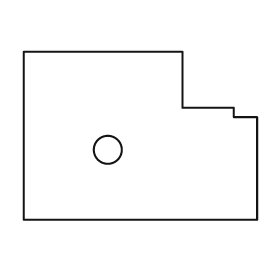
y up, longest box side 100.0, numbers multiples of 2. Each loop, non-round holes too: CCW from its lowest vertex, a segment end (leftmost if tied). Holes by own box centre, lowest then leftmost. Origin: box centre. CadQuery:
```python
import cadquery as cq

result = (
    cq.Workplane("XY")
    .moveTo(-50.0, -36.0)
    .lineTo(50.0, -36.0)
    .lineTo(50.0, 8.0)
    .lineTo(40.0, 8.0)
    .lineTo(40.0, 12.0)
    .lineTo(18.0, 12.0)
    .lineTo(18.0, 36.0)
    .lineTo(-50.0, 36.0)
    .close()
    .moveTo(-14.0, -6.0)
    .circle(6.0)
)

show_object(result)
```